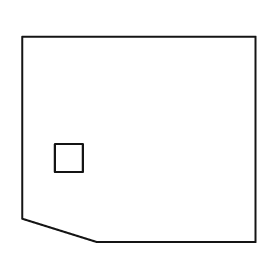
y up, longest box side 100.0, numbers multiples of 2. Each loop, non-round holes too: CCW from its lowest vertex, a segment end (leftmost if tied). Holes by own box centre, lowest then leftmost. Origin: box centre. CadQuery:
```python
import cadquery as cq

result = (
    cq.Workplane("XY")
    .moveTo(-18.0, -44.0)
    .lineTo(50.0, -44.0)
    .lineTo(50.0, 44.0)
    .lineTo(-50.0, 44.0)
    .lineTo(-50.0, -34.0)
    .close()
    .moveTo(-36.0, -14.0)
    .lineTo(-24.0, -14.0)
    .lineTo(-24.0, -2.0)
    .lineTo(-36.0, -2.0)
    .close()
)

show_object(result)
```